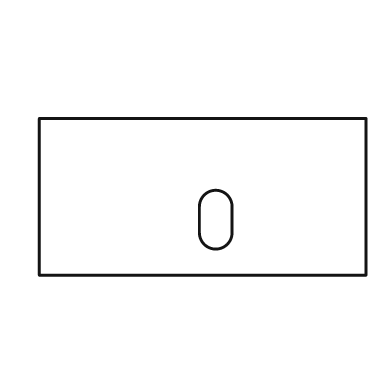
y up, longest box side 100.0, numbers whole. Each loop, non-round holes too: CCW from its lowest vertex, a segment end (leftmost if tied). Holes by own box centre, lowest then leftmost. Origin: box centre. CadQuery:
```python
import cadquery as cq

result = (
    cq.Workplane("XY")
    .moveTo(-50.0, -24.0)
    .lineTo(50.0, -24.0)
    .lineTo(50.0, 24.0)
    .lineTo(-50.0, 24.0)
    .close()
    .moveTo(-1.0, -11.0)
    .threePointArc((4.0, -16.0), (9.0, -11.0))
    .lineTo(9.0, -3.0)
    .threePointArc((4.0, 2.0), (-1.0, -3.0))
    .close()
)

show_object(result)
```